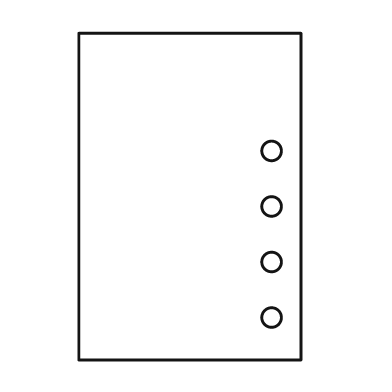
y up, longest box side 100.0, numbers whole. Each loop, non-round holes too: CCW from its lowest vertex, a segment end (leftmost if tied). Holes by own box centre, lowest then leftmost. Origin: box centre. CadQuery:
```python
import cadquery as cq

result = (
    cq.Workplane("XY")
    .moveTo(-34.0, -50.0)
    .lineTo(34.0, -50.0)
    .lineTo(34.0, 50.0)
    .lineTo(-34.0, 50.0)
    .close()
    .moveTo(25.0, -37.0)
    .circle(3.0)
    .moveTo(25.0, -20.0)
    .circle(3.0)
    .moveTo(25.0, -3.0)
    .circle(3.0)
    .moveTo(25.0, 14.0)
    .circle(3.0)
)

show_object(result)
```